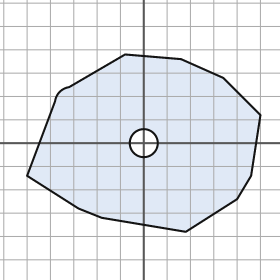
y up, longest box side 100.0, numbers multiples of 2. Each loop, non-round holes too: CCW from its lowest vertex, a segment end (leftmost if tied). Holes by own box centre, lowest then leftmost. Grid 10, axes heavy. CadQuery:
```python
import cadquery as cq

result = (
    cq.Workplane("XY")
    .moveTo(18.0, -38.0)
    .lineTo(40.0, -24.0)
    .lineTo(46.0, -14.0)
    .lineTo(50.0, 12.0)
    .lineTo(34.0, 28.0)
    .lineTo(16.0, 36.0)
    .lineTo(-8.0, 38.0)
    .lineTo(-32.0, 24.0)
    .threePointArc((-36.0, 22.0), (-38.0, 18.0))
    .lineTo(-50.0, -14.0)
    .lineTo(-28.0, -28.0)
    .lineTo(-18.0, -32.0)
    .close()
    .moveTo(0.0, 0.0)
    .circle(6.0)
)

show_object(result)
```